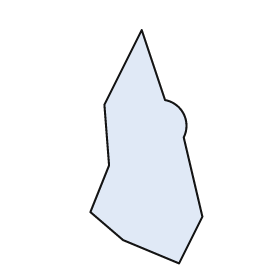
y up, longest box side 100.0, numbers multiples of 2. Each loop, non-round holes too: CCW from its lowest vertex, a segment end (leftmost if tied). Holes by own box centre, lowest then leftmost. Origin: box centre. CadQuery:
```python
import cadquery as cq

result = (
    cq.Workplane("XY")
    .moveTo(14.0, -50.0)
    .lineTo(24.0, -30.0)
    .lineTo(16.0, 4.0)
    .threePointArc((16.0, 14.0), (8.0, 20.0))
    .lineTo(-2.0, 50.0)
    .lineTo(-18.0, 18.0)
    .lineTo(-16.0, -8.0)
    .lineTo(-24.0, -28.0)
    .lineTo(-10.0, -40.0)
    .close()
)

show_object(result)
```